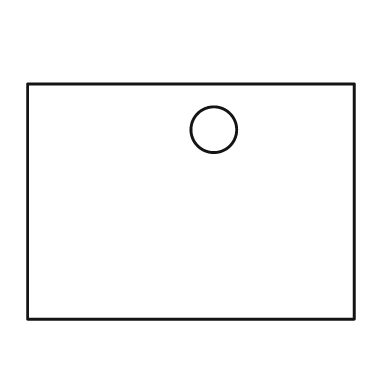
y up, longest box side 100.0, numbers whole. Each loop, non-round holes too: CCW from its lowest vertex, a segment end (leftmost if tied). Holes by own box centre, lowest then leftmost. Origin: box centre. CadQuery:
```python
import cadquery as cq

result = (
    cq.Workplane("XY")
    .moveTo(-50.0, -36.0)
    .lineTo(50.0, -36.0)
    .lineTo(50.0, 36.0)
    .lineTo(-50.0, 36.0)
    .close()
    .moveTo(7.0, 22.0)
    .circle(7.0)
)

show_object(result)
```